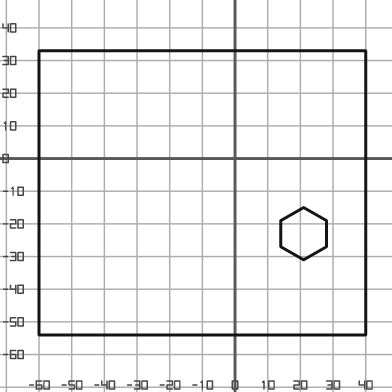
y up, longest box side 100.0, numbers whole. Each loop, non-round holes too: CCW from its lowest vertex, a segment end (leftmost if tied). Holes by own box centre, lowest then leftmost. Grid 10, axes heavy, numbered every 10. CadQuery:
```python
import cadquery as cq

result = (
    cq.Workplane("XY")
    .moveTo(-60.0, -54.0)
    .lineTo(40.0, -54.0)
    .lineTo(40.0, 33.0)
    .lineTo(-60.0, 33.0)
    .close()
    .moveTo(21.0, -31.0)
    .lineTo(28.0, -27.0)
    .lineTo(28.0, -19.0)
    .lineTo(21.0, -15.0)
    .lineTo(14.0, -19.0)
    .lineTo(14.0, -27.0)
    .close()
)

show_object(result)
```